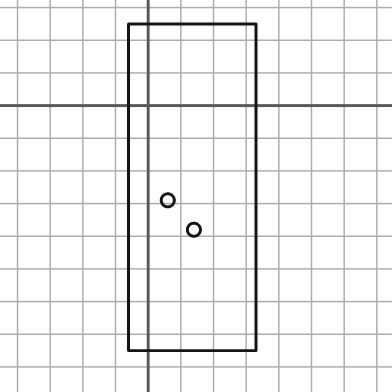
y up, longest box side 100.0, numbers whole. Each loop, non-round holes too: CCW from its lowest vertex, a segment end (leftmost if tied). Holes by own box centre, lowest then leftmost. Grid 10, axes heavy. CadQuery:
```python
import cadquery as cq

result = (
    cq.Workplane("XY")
    .moveTo(-6.0, -75.0)
    .lineTo(33.0, -75.0)
    .lineTo(33.0, 25.0)
    .lineTo(-6.0, 25.0)
    .close()
    .moveTo(14.0, -38.0)
    .circle(2.0)
    .moveTo(6.0, -29.0)
    .circle(2.0)
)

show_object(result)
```